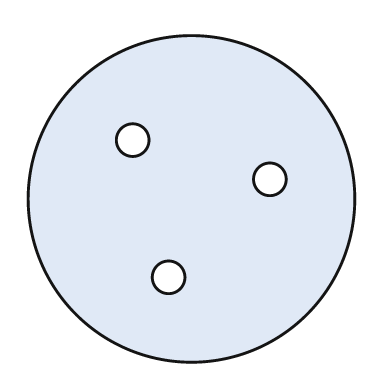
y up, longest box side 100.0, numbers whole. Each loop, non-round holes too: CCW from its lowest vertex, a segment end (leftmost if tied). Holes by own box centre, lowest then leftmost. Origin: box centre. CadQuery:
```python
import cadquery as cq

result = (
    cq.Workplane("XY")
    .moveTo(0.0, 0.0)
    .circle(50.0)
    .moveTo(-7.0, -24.0)
    .circle(5.0)
    .moveTo(24.0, 6.0)
    .circle(5.0)
    .moveTo(-18.0, 18.0)
    .circle(5.0)
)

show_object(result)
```